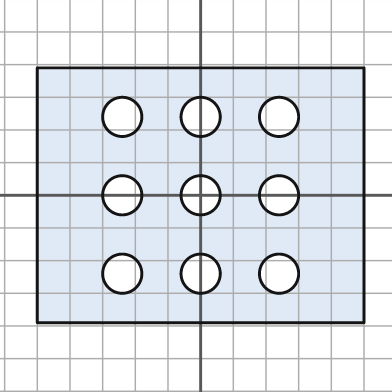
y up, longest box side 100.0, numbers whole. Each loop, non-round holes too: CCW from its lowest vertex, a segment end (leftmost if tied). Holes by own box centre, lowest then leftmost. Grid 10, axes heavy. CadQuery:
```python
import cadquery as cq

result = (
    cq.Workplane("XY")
    .moveTo(-50.0, -39.0)
    .lineTo(50.0, -39.0)
    .lineTo(50.0, 39.0)
    .lineTo(-50.0, 39.0)
    .close()
    .moveTo(-24.0, -24.0)
    .circle(6.0)
    .moveTo(0.0, -24.0)
    .circle(6.0)
    .moveTo(24.0, -24.0)
    .circle(6.0)
    .moveTo(-24.0, 0.0)
    .circle(6.0)
    .moveTo(0.0, 0.0)
    .circle(6.0)
    .moveTo(24.0, 0.0)
    .circle(6.0)
    .moveTo(-24.0, 24.0)
    .circle(6.0)
    .moveTo(0.0, 24.0)
    .circle(6.0)
    .moveTo(24.0, 24.0)
    .circle(6.0)
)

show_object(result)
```